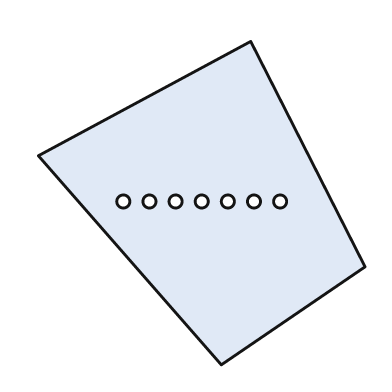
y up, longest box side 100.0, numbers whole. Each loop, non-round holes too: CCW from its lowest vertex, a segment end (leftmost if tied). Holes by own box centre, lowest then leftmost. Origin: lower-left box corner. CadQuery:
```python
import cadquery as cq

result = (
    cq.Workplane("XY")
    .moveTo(56.0, 0.0)
    .lineTo(100.0, 30.0)
    .lineTo(65.0, 99.0)
    .lineTo(0.0, 64.0)
    .close()
    .moveTo(26.0, 50.0)
    .circle(2.0)
    .moveTo(34.0, 50.0)
    .circle(2.0)
    .moveTo(42.0, 50.0)
    .circle(2.0)
    .moveTo(50.0, 50.0)
    .circle(2.0)
    .moveTo(58.0, 50.0)
    .circle(2.0)
    .moveTo(66.0, 50.0)
    .circle(2.0)
    .moveTo(74.0, 50.0)
    .circle(2.0)
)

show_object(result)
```